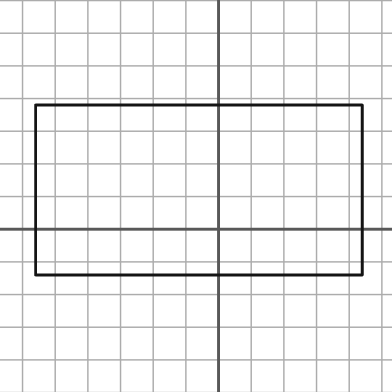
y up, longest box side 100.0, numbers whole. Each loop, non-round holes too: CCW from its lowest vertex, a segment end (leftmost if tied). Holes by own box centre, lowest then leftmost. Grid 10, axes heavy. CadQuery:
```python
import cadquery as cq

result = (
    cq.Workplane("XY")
    .moveTo(-56.0, -14.0)
    .lineTo(44.0, -14.0)
    .lineTo(44.0, 38.0)
    .lineTo(-56.0, 38.0)
    .close()
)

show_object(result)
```